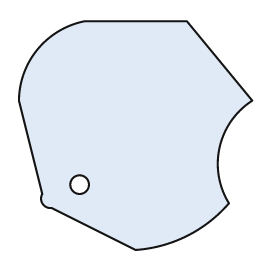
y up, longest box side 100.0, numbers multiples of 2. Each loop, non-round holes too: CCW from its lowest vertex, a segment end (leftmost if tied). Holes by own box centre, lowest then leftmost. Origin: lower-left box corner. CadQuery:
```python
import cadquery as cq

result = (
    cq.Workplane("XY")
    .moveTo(50.0, 0.0)
    .threePointArc((72.0, 6.0), (90.0, 20.0))
    .threePointArc((86.0, 44.0), (100.0, 64.0))
    .lineTo(72.0, 98.0)
    .lineTo(28.0, 98.0)
    .threePointArc((8.0, 86.0), (0.0, 64.0))
    .lineTo(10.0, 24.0)
    .threePointArc((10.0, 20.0), (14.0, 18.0))
    .close()
    .moveTo(26.0, 28.0)
    .circle(4.0)
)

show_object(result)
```